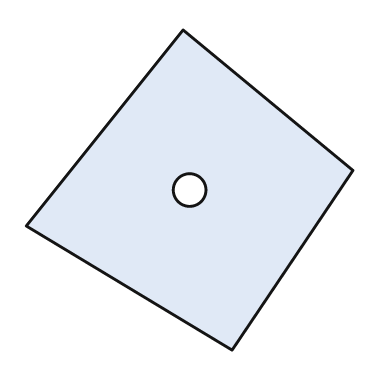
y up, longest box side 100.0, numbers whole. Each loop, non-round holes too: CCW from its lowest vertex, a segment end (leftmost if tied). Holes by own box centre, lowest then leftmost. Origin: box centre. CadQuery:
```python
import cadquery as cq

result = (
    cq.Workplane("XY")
    .moveTo(13.0, -49.0)
    .lineTo(50.0, 6.0)
    .lineTo(-2.0, 49.0)
    .lineTo(-50.0, -11.0)
    .close()
    .moveTo(0.0, 0.0)
    .circle(5.0)
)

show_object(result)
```